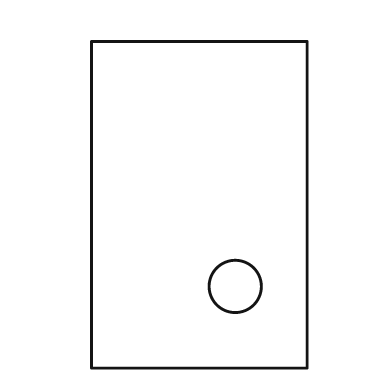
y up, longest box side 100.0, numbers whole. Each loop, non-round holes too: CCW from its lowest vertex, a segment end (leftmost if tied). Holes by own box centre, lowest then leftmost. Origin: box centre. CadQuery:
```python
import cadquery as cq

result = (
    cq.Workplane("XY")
    .moveTo(-33.0, -50.0)
    .lineTo(33.0, -50.0)
    .lineTo(33.0, 50.0)
    .lineTo(-33.0, 50.0)
    .close()
    .moveTo(11.0, -25.0)
    .circle(8.0)
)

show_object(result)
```